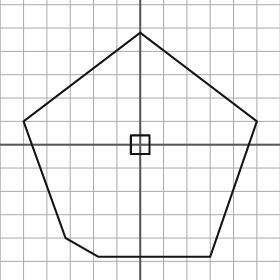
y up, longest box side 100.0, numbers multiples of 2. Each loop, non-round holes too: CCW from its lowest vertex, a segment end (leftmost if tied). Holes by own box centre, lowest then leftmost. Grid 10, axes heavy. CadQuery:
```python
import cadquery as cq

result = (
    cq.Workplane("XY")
    .moveTo(-18.0, -48.0)
    .lineTo(30.0, -48.0)
    .lineTo(50.0, 10.0)
    .lineTo(0.0, 48.0)
    .lineTo(-50.0, 10.0)
    .lineTo(-32.0, -40.0)
    .close()
    .moveTo(-4.0, -4.0)
    .lineTo(4.0, -4.0)
    .lineTo(4.0, 4.0)
    .lineTo(-4.0, 4.0)
    .close()
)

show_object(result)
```